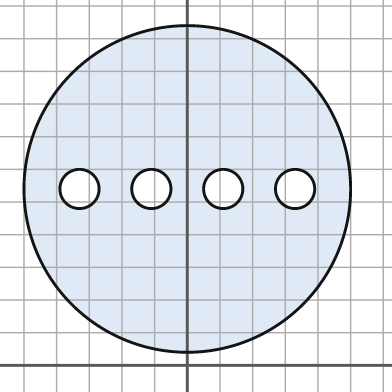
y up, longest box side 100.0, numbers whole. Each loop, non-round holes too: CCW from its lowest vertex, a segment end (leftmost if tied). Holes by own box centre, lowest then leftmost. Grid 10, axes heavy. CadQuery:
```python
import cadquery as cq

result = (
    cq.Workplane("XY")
    .moveTo(0.0, 54.0)
    .circle(50.0)
    .moveTo(-33.0, 54.0)
    .circle(6.0)
    .moveTo(-11.0, 54.0)
    .circle(6.0)
    .moveTo(11.0, 54.0)
    .circle(6.0)
    .moveTo(33.0, 54.0)
    .circle(6.0)
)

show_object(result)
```